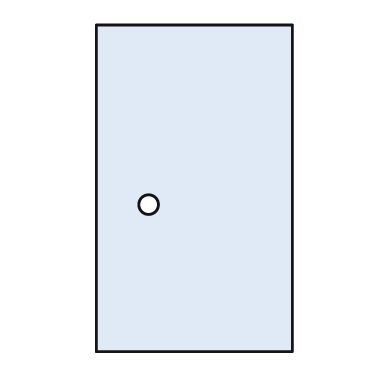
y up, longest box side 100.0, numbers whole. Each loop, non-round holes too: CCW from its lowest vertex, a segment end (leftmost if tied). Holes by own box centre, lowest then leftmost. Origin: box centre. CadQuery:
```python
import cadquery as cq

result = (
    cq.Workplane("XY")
    .moveTo(-30.0, -50.0)
    .lineTo(30.0, -50.0)
    .lineTo(30.0, 50.0)
    .lineTo(-30.0, 50.0)
    .close()
    .moveTo(-14.0, -5.0)
    .circle(3.0)
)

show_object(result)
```